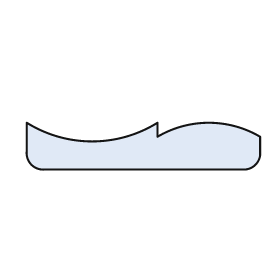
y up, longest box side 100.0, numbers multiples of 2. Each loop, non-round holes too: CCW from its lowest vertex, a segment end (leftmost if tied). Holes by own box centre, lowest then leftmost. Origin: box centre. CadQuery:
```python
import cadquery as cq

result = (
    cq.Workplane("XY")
    .moveTo(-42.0, -10.0)
    .lineTo(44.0, -10.0)
    .threePointArc((48.0, -8.0), (50.0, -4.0))
    .lineTo(50.0, 4.0)
    .threePointArc((28.0, 10.0), (6.0, 4.0))
    .lineTo(6.0, 10.0)
    .threePointArc((-22.0, 2.0), (-50.0, 10.0))
    .lineTo(-50.0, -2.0)
    .threePointArc((-48.0, -8.0), (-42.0, -10.0))
    .close()
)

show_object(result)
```